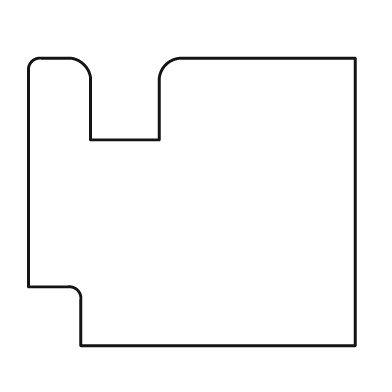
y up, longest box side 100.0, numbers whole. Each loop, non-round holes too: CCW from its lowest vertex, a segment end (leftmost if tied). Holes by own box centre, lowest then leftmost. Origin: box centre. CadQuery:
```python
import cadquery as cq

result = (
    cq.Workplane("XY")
    .moveTo(-34.0, -44.0)
    .lineTo(50.0, -44.0)
    .lineTo(50.0, 44.0)
    .lineTo(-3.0, 44.0)
    .threePointArc((-8.0, 42.0), (-10.0, 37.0))
    .lineTo(-10.0, 19.0)
    .lineTo(-31.0, 19.0)
    .lineTo(-31.0, 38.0)
    .threePointArc((-33.0, 42.0), (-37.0, 44.0))
    .lineTo(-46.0, 44.0)
    .threePointArc((-49.0, 43.0), (-50.0, 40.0))
    .lineTo(-50.0, -26.0)
    .lineTo(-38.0, -26.0)
    .threePointArc((-35.0, -27.0), (-34.0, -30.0))
    .close()
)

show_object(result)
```